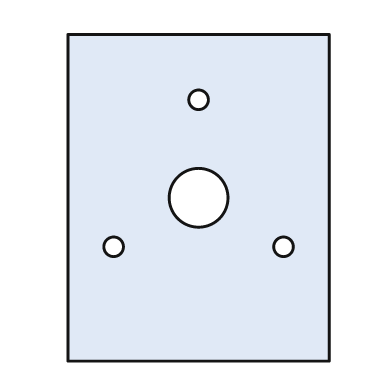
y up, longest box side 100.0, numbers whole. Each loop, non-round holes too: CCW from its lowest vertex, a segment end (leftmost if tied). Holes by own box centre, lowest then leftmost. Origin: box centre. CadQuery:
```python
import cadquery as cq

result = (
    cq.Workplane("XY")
    .moveTo(-40.0, -50.0)
    .lineTo(40.0, -50.0)
    .lineTo(40.0, 50.0)
    .lineTo(-40.0, 50.0)
    .close()
    .moveTo(-26.0, -15.0)
    .circle(3.0)
    .moveTo(26.0, -15.0)
    .circle(3.0)
    .moveTo(0.0, 0.0)
    .circle(9.0)
    .moveTo(0.0, 30.0)
    .circle(3.0)
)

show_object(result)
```